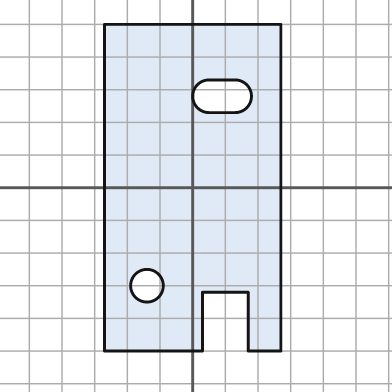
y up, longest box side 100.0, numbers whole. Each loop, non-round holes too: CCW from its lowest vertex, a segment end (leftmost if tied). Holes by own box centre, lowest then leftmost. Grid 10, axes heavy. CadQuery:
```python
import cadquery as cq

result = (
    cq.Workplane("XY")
    .moveTo(-27.0, -50.0)
    .lineTo(3.0, -50.0)
    .lineTo(3.0, -32.0)
    .lineTo(17.0, -32.0)
    .lineTo(17.0, -50.0)
    .lineTo(27.0, -50.0)
    .lineTo(27.0, 50.0)
    .lineTo(-27.0, 50.0)
    .close()
    .moveTo(-14.0, -30.0)
    .circle(5.0)
    .moveTo(5.0, 23.0)
    .lineTo(13.0, 23.0)
    .threePointArc((18.0, 28.0), (13.0, 33.0))
    .lineTo(5.0, 33.0)
    .threePointArc((0.0, 28.0), (5.0, 23.0))
    .close()
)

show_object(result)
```